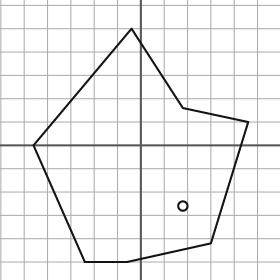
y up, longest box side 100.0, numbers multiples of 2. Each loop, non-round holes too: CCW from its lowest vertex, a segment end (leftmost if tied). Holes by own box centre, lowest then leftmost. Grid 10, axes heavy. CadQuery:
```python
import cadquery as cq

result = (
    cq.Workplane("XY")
    .moveTo(-24.0, -50.0)
    .lineTo(-6.0, -50.0)
    .lineTo(30.0, -42.0)
    .lineTo(46.0, 10.0)
    .lineTo(18.0, 16.0)
    .lineTo(-4.0, 50.0)
    .lineTo(-46.0, 0.0)
    .close()
    .moveTo(18.0, -26.0)
    .circle(2.0)
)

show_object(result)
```